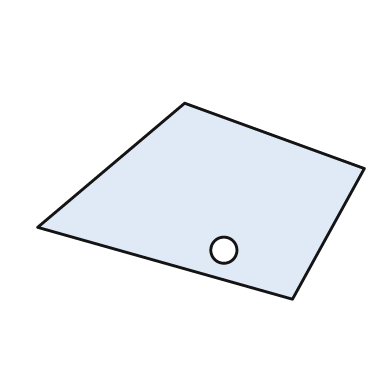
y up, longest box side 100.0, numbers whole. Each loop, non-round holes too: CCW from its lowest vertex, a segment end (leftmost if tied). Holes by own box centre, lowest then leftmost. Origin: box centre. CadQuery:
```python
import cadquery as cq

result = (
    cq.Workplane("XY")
    .moveTo(28.0, -30.0)
    .lineTo(50.0, 10.0)
    .lineTo(-5.0, 30.0)
    .lineTo(-50.0, -8.0)
    .close()
    .moveTo(7.0, -15.0)
    .circle(4.0)
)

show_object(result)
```